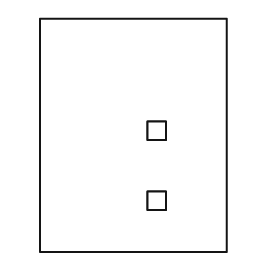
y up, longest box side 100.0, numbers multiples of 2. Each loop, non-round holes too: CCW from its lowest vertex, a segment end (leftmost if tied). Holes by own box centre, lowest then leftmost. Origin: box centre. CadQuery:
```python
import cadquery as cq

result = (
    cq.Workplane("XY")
    .moveTo(-40.0, -50.0)
    .lineTo(40.0, -50.0)
    .lineTo(40.0, 50.0)
    .lineTo(-40.0, 50.0)
    .close()
    .moveTo(6.0, -32.0)
    .lineTo(14.0, -32.0)
    .lineTo(14.0, -24.0)
    .lineTo(6.0, -24.0)
    .close()
    .moveTo(6.0, -2.0)
    .lineTo(14.0, -2.0)
    .lineTo(14.0, 6.0)
    .lineTo(6.0, 6.0)
    .close()
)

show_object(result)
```